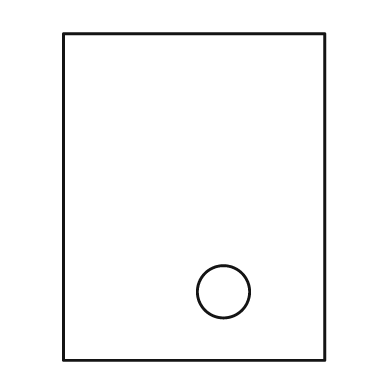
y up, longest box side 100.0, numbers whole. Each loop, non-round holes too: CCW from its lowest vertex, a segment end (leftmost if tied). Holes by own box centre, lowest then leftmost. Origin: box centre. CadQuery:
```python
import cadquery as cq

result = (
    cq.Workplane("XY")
    .moveTo(-40.0, -50.0)
    .lineTo(40.0, -50.0)
    .lineTo(40.0, 50.0)
    .lineTo(-40.0, 50.0)
    .close()
    .moveTo(9.0, -29.0)
    .circle(8.0)
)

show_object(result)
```